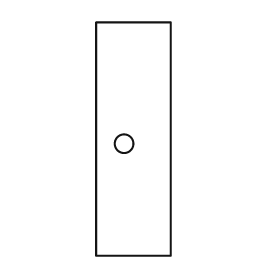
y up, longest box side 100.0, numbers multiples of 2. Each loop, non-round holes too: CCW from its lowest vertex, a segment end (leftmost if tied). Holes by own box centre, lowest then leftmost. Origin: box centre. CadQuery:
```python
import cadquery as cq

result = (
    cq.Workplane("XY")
    .moveTo(-16.0, -50.0)
    .lineTo(16.0, -50.0)
    .lineTo(16.0, 50.0)
    .lineTo(-16.0, 50.0)
    .close()
    .moveTo(-4.0, -2.0)
    .circle(4.0)
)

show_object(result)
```